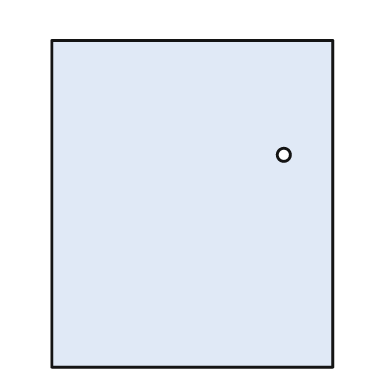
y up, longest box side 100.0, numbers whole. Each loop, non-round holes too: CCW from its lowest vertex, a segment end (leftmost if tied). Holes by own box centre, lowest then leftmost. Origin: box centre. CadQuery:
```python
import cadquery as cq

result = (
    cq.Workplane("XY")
    .moveTo(-43.0, -50.0)
    .lineTo(43.0, -50.0)
    .lineTo(43.0, 50.0)
    .lineTo(-43.0, 50.0)
    .close()
    .moveTo(28.0, 15.0)
    .circle(2.0)
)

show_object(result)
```